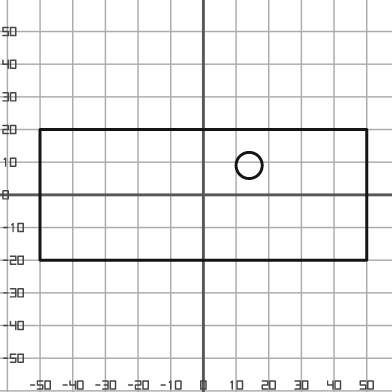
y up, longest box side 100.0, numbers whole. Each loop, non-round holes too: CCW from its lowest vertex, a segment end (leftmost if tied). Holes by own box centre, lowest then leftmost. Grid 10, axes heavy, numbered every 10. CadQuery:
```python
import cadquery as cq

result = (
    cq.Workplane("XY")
    .moveTo(-50.0, -20.0)
    .lineTo(50.0, -20.0)
    .lineTo(50.0, 20.0)
    .lineTo(-50.0, 20.0)
    .close()
    .moveTo(14.0, 9.0)
    .circle(4.0)
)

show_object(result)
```